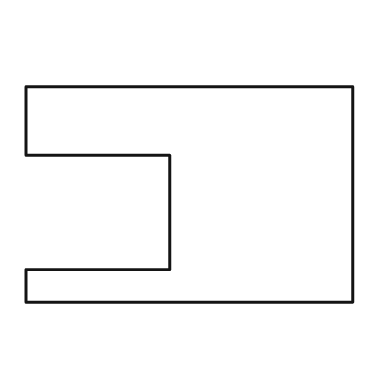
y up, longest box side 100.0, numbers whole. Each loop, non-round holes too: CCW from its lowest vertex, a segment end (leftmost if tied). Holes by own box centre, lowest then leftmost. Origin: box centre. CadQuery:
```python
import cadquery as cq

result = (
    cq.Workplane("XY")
    .moveTo(-50.0, -33.0)
    .lineTo(50.0, -33.0)
    .lineTo(50.0, 33.0)
    .lineTo(-50.0, 33.0)
    .lineTo(-50.0, 12.0)
    .lineTo(-6.0, 12.0)
    .lineTo(-6.0, -23.0)
    .lineTo(-50.0, -23.0)
    .close()
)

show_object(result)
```